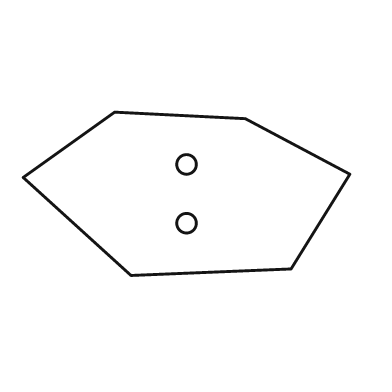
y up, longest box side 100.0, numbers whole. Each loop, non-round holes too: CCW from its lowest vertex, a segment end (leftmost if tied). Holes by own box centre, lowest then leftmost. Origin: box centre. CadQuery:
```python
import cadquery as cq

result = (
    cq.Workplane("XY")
    .moveTo(-17.0, -25.0)
    .lineTo(32.0, -23.0)
    .lineTo(50.0, 6.0)
    .lineTo(18.0, 23.0)
    .lineTo(-22.0, 25.0)
    .lineTo(-50.0, 5.0)
    .close()
    .moveTo(0.0, -9.0)
    .circle(3.0)
    .moveTo(0.0, 9.0)
    .circle(3.0)
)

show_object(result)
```